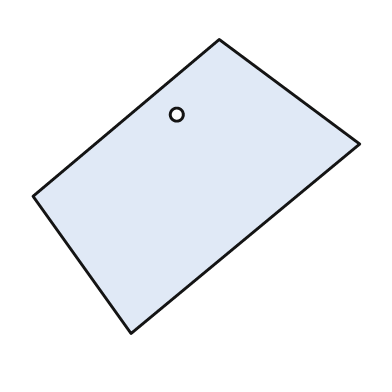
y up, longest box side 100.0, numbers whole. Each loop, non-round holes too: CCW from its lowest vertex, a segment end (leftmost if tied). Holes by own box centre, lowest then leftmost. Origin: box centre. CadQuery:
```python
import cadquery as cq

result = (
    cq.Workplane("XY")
    .moveTo(-20.0, -45.0)
    .lineTo(50.0, 13.0)
    .lineTo(7.0, 45.0)
    .lineTo(-50.0, -3.0)
    .close()
    .moveTo(-6.0, 22.0)
    .circle(2.0)
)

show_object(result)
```